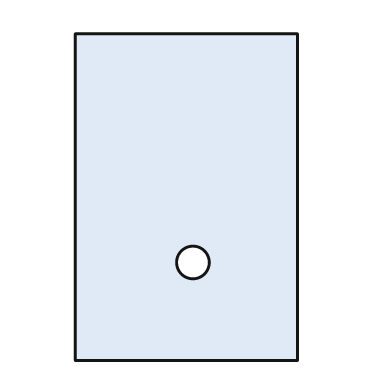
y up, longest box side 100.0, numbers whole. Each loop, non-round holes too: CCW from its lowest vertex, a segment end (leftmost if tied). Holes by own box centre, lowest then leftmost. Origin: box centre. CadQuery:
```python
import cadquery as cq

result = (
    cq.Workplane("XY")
    .moveTo(-34.0, -50.0)
    .lineTo(34.0, -50.0)
    .lineTo(34.0, 50.0)
    .lineTo(-34.0, 50.0)
    .close()
    .moveTo(2.0, -20.0)
    .circle(5.0)
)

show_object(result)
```